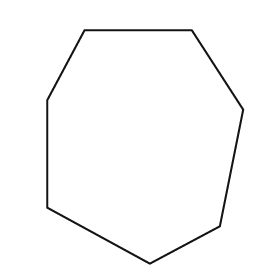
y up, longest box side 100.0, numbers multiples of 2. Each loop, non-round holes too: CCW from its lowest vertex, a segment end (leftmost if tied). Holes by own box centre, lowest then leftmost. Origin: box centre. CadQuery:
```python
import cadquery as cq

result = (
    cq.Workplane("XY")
    .moveTo(2.0, -50.0)
    .lineTo(32.0, -34.0)
    .lineTo(42.0, 16.0)
    .lineTo(20.0, 50.0)
    .lineTo(-26.0, 50.0)
    .lineTo(-42.0, 20.0)
    .lineTo(-42.0, -26.0)
    .close()
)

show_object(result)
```